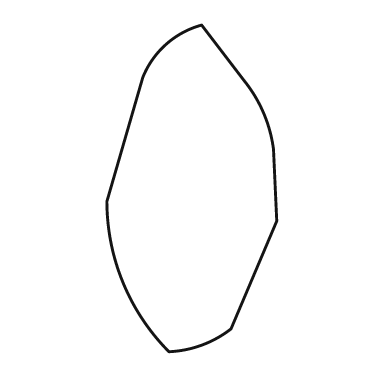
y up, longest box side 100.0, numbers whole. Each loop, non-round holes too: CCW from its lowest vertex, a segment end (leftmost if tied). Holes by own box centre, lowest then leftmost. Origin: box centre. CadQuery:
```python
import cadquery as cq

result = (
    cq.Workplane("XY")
    .moveTo(-7.0, -50.0)
    .threePointArc((3.0, -48.0), (12.0, -43.0))
    .lineTo(26.0, -10.0)
    .lineTo(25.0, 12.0)
    .threePointArc((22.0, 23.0), (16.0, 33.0))
    .lineTo(3.0, 50.0)
    .threePointArc((-8.0, 44.0), (-15.0, 34.0))
    .lineTo(-26.0, -4.0)
    .threePointArc((-21.0, -29.0), (-7.0, -50.0))
    .close()
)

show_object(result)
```